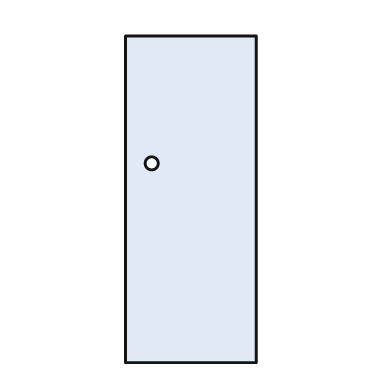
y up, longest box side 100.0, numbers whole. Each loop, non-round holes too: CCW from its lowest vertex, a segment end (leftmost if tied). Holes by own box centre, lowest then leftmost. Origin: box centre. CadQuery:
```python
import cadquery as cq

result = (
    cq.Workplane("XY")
    .moveTo(-20.0, -50.0)
    .lineTo(20.0, -50.0)
    .lineTo(20.0, 50.0)
    .lineTo(-20.0, 50.0)
    .close()
    .moveTo(-12.0, 11.0)
    .circle(2.0)
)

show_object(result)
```